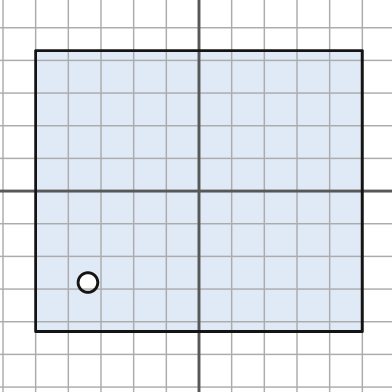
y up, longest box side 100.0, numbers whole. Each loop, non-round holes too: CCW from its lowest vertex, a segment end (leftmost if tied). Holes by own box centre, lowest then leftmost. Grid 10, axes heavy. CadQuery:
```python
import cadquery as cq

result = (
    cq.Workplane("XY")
    .moveTo(-50.0, -43.0)
    .lineTo(50.0, -43.0)
    .lineTo(50.0, 43.0)
    .lineTo(-50.0, 43.0)
    .close()
    .moveTo(-34.0, -28.0)
    .circle(3.0)
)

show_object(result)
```